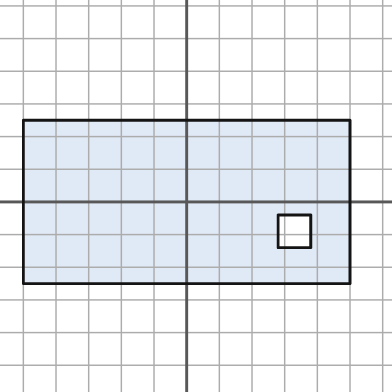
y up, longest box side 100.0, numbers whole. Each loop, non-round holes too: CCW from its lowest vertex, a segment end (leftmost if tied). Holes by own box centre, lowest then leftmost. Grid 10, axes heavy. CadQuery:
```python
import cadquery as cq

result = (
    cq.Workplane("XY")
    .moveTo(-50.0, -25.0)
    .lineTo(50.0, -25.0)
    .lineTo(50.0, 25.0)
    .lineTo(-50.0, 25.0)
    .close()
    .moveTo(28.0, -14.0)
    .lineTo(38.0, -14.0)
    .lineTo(38.0, -4.0)
    .lineTo(28.0, -4.0)
    .close()
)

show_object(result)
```